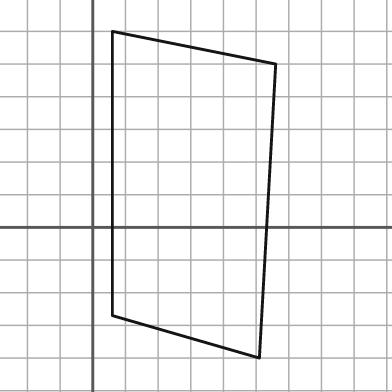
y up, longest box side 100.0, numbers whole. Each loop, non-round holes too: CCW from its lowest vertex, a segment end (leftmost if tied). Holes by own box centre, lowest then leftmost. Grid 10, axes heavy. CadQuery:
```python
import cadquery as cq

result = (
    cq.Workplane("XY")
    .moveTo(51.0, -40.0)
    .lineTo(56.0, 50.0)
    .lineTo(6.0, 60.0)
    .lineTo(6.0, -27.0)
    .close()
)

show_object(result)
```